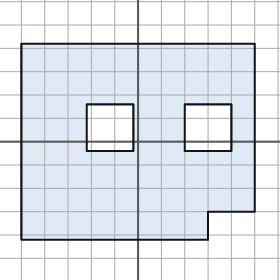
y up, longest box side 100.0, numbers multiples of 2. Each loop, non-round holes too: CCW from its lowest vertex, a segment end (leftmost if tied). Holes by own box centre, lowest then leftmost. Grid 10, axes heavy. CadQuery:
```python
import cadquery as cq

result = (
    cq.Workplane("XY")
    .moveTo(-50.0, -42.0)
    .lineTo(30.0, -42.0)
    .lineTo(30.0, -30.0)
    .lineTo(50.0, -30.0)
    .lineTo(50.0, 42.0)
    .lineTo(-50.0, 42.0)
    .close()
    .moveTo(-22.0, -4.0)
    .lineTo(-2.0, -4.0)
    .lineTo(-2.0, 16.0)
    .lineTo(-22.0, 16.0)
    .close()
    .moveTo(20.0, -4.0)
    .lineTo(40.0, -4.0)
    .lineTo(40.0, 16.0)
    .lineTo(20.0, 16.0)
    .close()
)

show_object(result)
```